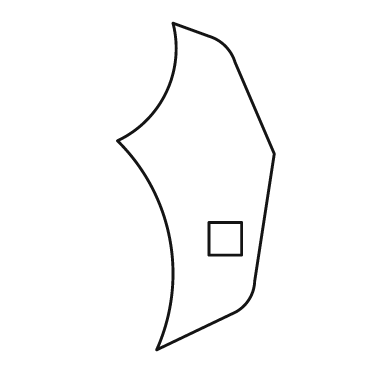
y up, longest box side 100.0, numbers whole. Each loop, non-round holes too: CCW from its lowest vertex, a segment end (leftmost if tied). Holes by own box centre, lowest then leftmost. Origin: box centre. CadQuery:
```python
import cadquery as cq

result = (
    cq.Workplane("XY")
    .moveTo(-12.0, -50.0)
    .lineTo(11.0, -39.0)
    .threePointArc((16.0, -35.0), (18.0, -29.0))
    .lineTo(24.0, 10.0)
    .lineTo(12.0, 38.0)
    .threePointArc((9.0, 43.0), (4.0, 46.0))
    .lineTo(-7.0, 50.0)
    .threePointArc((-9.0, 29.0), (-24.0, 14.0))
    .threePointArc((-8.0, -16.0), (-12.0, -50.0))
    .close()
    .moveTo(4.0, -21.0)
    .lineTo(14.0, -21.0)
    .lineTo(14.0, -11.0)
    .lineTo(4.0, -11.0)
    .close()
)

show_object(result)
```